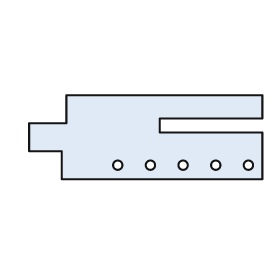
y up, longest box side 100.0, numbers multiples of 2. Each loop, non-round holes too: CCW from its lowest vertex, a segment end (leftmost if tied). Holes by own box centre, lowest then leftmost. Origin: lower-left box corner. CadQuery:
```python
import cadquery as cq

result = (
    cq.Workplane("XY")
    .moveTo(14.0, 0.0)
    .lineTo(100.0, 0.0)
    .lineTo(100.0, 20.0)
    .lineTo(56.0, 20.0)
    .lineTo(56.0, 26.0)
    .lineTo(100.0, 26.0)
    .lineTo(100.0, 36.0)
    .lineTo(16.0, 36.0)
    .lineTo(16.0, 24.0)
    .lineTo(0.0, 24.0)
    .lineTo(0.0, 12.0)
    .lineTo(14.0, 12.0)
    .close()
    .moveTo(38.0, 6.0)
    .circle(2.0)
    .moveTo(52.0, 6.0)
    .circle(2.0)
    .moveTo(66.0, 6.0)
    .circle(2.0)
    .moveTo(80.0, 6.0)
    .circle(2.0)
    .moveTo(94.0, 6.0)
    .circle(2.0)
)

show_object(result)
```